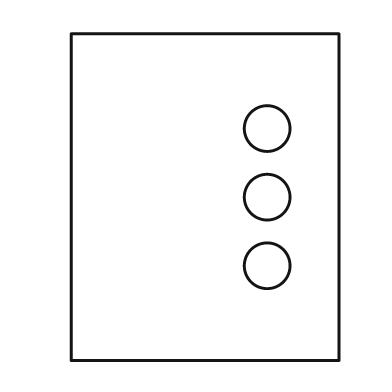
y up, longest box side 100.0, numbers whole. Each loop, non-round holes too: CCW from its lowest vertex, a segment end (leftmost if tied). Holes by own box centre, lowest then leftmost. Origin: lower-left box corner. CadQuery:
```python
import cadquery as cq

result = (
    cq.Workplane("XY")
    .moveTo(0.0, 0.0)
    .lineTo(82.0, 0.0)
    .lineTo(82.0, 100.0)
    .lineTo(0.0, 100.0)
    .close()
    .moveTo(60.0, 29.0)
    .circle(7.0)
    .moveTo(60.0, 50.0)
    .circle(7.0)
    .moveTo(60.0, 71.0)
    .circle(7.0)
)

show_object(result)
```